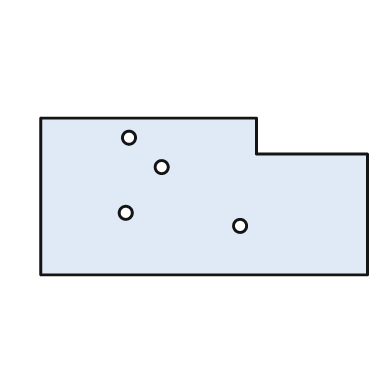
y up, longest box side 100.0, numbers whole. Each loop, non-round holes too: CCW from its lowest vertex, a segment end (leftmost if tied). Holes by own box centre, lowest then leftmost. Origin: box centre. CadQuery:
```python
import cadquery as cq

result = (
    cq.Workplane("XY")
    .moveTo(-50.0, -24.0)
    .lineTo(50.0, -24.0)
    .lineTo(50.0, 13.0)
    .lineTo(16.0, 13.0)
    .lineTo(16.0, 24.0)
    .lineTo(-50.0, 24.0)
    .close()
    .moveTo(11.0, -9.0)
    .circle(2.0)
    .moveTo(-24.0, -5.0)
    .circle(2.0)
    .moveTo(-13.0, 9.0)
    .circle(2.0)
    .moveTo(-23.0, 18.0)
    .circle(2.0)
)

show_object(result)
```